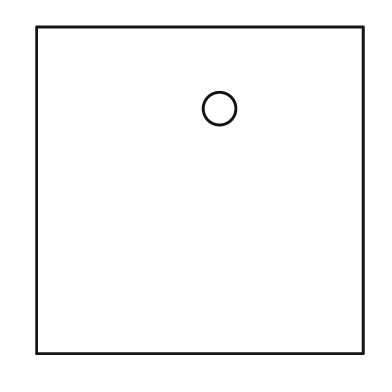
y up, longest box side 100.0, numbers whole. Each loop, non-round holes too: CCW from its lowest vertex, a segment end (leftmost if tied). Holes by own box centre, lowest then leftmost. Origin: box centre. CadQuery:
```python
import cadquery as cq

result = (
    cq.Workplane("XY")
    .moveTo(-50.0, -50.0)
    .lineTo(50.0, -50.0)
    .lineTo(50.0, 50.0)
    .lineTo(-50.0, 50.0)
    .close()
    .moveTo(6.0, 25.0)
    .circle(5.0)
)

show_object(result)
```